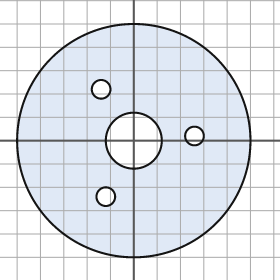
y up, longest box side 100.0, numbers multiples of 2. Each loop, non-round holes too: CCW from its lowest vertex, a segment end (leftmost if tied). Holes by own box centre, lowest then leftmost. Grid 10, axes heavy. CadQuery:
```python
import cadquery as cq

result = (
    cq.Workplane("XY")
    .moveTo(0.0, 0.0)
    .circle(50.0)
    .moveTo(-12.0, -24.0)
    .circle(4.0)
    .moveTo(0.0, 0.0)
    .circle(12.0)
    .moveTo(26.0, 2.0)
    .circle(4.0)
    .moveTo(-14.0, 22.0)
    .circle(4.0)
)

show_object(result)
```